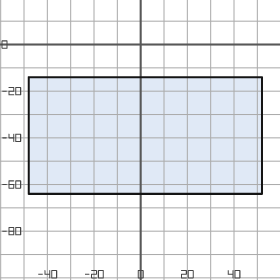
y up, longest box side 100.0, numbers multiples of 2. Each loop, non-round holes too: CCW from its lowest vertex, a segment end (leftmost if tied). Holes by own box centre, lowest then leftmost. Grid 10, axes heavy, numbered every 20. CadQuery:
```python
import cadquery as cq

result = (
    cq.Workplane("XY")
    .moveTo(-48.0, -64.0)
    .lineTo(52.0, -64.0)
    .lineTo(52.0, -14.0)
    .lineTo(-48.0, -14.0)
    .close()
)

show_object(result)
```